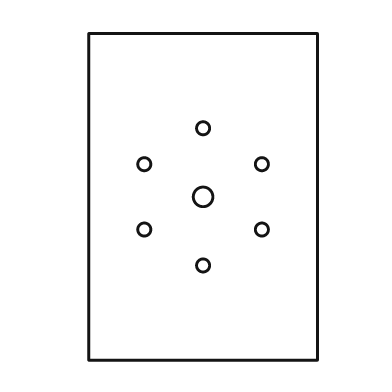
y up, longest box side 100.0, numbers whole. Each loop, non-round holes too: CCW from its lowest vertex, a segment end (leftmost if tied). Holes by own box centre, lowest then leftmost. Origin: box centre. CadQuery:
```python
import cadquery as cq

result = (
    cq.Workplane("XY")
    .moveTo(-35.0, -50.0)
    .lineTo(35.0, -50.0)
    .lineTo(35.0, 50.0)
    .lineTo(-35.0, 50.0)
    .close()
    .moveTo(0.0, -21.0)
    .circle(2.0)
    .moveTo(-18.0, -10.0)
    .circle(2.0)
    .moveTo(18.0, -10.0)
    .circle(2.0)
    .moveTo(0.0, 0.0)
    .circle(3.0)
    .moveTo(-18.0, 10.0)
    .circle(2.0)
    .moveTo(18.0, 10.0)
    .circle(2.0)
    .moveTo(0.0, 21.0)
    .circle(2.0)
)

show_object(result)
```